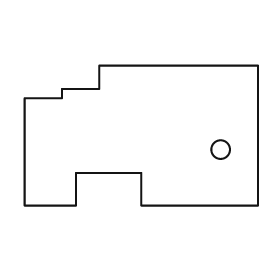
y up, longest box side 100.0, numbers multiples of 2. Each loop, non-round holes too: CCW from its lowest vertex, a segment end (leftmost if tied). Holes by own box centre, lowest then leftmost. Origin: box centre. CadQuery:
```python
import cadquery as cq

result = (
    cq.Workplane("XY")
    .moveTo(-50.0, -30.0)
    .lineTo(-28.0, -30.0)
    .lineTo(-28.0, -16.0)
    .lineTo(0.0, -16.0)
    .lineTo(0.0, -30.0)
    .lineTo(50.0, -30.0)
    .lineTo(50.0, 30.0)
    .lineTo(-18.0, 30.0)
    .lineTo(-18.0, 20.0)
    .lineTo(-34.0, 20.0)
    .lineTo(-34.0, 16.0)
    .lineTo(-50.0, 16.0)
    .close()
    .moveTo(34.0, -6.0)
    .circle(4.0)
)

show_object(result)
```